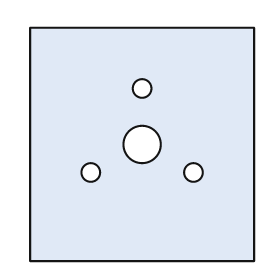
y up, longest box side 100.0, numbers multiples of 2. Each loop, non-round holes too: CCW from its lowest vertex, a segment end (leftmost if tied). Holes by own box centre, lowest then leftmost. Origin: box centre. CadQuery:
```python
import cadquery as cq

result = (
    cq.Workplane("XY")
    .moveTo(-48.0, -50.0)
    .lineTo(48.0, -50.0)
    .lineTo(48.0, 50.0)
    .lineTo(-48.0, 50.0)
    .close()
    .moveTo(-22.0, -12.0)
    .circle(4.0)
    .moveTo(22.0, -12.0)
    .circle(4.0)
    .moveTo(0.0, 0.0)
    .circle(8.0)
    .moveTo(0.0, 24.0)
    .circle(4.0)
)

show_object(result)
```